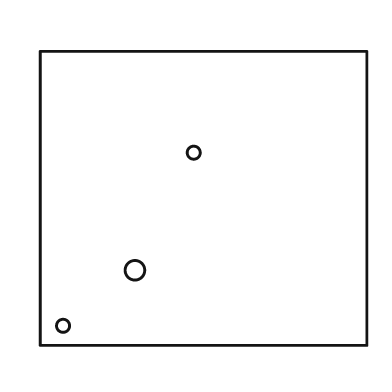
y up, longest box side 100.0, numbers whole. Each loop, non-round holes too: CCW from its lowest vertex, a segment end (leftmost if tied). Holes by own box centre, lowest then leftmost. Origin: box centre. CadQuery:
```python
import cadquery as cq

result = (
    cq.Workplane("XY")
    .moveTo(-50.0, -45.0)
    .lineTo(50.0, -45.0)
    .lineTo(50.0, 45.0)
    .lineTo(-50.0, 45.0)
    .close()
    .moveTo(-43.0, -39.0)
    .circle(2.0)
    .moveTo(-21.0, -22.0)
    .circle(3.0)
    .moveTo(-3.0, 14.0)
    .circle(2.0)
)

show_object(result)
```